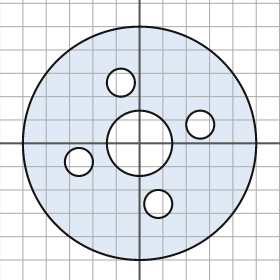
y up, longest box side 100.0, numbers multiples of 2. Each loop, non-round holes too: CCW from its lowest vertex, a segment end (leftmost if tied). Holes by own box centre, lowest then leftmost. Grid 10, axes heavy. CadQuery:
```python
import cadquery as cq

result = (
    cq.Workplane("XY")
    .moveTo(0.0, 0.0)
    .circle(50.0)
    .moveTo(8.0, -26.0)
    .circle(6.0)
    .moveTo(-26.0, -8.0)
    .circle(6.0)
    .moveTo(0.0, 0.0)
    .circle(14.0)
    .moveTo(26.0, 8.0)
    .circle(6.0)
    .moveTo(-8.0, 26.0)
    .circle(6.0)
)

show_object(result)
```